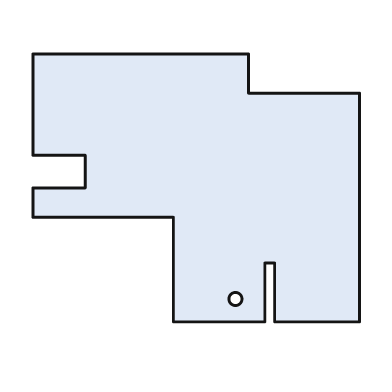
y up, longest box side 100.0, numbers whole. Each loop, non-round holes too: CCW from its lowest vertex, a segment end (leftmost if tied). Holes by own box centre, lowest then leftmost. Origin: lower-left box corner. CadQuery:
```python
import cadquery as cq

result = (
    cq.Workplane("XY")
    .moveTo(43.0, 0.0)
    .lineTo(71.0, 0.0)
    .lineTo(71.0, 18.0)
    .lineTo(74.0, 18.0)
    .lineTo(74.0, 0.0)
    .lineTo(100.0, 0.0)
    .lineTo(100.0, 70.0)
    .lineTo(66.0, 70.0)
    .lineTo(66.0, 82.0)
    .lineTo(0.0, 82.0)
    .lineTo(0.0, 51.0)
    .lineTo(16.0, 51.0)
    .lineTo(16.0, 41.0)
    .lineTo(0.0, 41.0)
    .lineTo(0.0, 32.0)
    .lineTo(43.0, 32.0)
    .close()
    .moveTo(62.0, 7.0)
    .circle(2.0)
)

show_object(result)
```